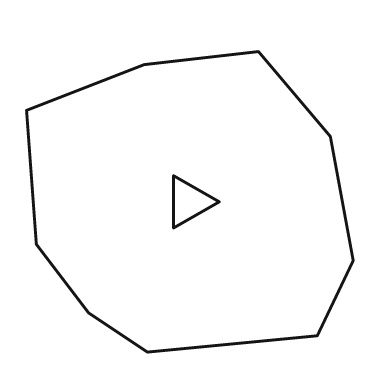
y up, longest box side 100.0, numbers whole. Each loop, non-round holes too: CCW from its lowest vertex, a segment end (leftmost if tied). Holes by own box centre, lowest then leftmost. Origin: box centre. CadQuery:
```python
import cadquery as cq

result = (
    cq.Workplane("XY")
    .moveTo(-13.0, -46.0)
    .lineTo(39.0, -41.0)
    .lineTo(50.0, -18.0)
    .lineTo(43.0, 20.0)
    .lineTo(21.0, 46.0)
    .lineTo(-14.0, 42.0)
    .lineTo(-50.0, 28.0)
    .lineTo(-47.0, -13.0)
    .lineTo(-31.0, -34.0)
    .close()
    .moveTo(-5.0, -8.0)
    .lineTo(9.0, 0.0)
    .lineTo(-5.0, 8.0)
    .close()
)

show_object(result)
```